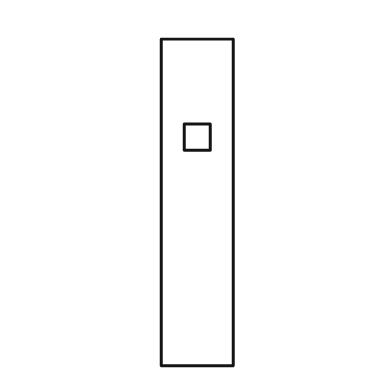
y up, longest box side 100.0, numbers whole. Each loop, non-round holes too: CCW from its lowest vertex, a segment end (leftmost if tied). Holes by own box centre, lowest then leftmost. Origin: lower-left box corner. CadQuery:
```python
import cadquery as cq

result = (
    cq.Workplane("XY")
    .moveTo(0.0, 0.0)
    .lineTo(22.0, 0.0)
    .lineTo(22.0, 100.0)
    .lineTo(0.0, 100.0)
    .close()
    .moveTo(7.0, 66.0)
    .lineTo(15.0, 66.0)
    .lineTo(15.0, 74.0)
    .lineTo(7.0, 74.0)
    .close()
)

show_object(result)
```